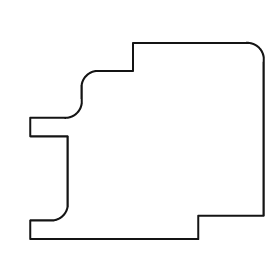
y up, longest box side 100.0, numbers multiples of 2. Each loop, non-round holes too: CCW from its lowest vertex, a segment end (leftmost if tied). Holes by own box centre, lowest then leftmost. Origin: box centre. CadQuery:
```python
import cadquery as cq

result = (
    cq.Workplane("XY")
    .moveTo(-50.0, -42.0)
    .lineTo(22.0, -42.0)
    .lineTo(22.0, -32.0)
    .lineTo(50.0, -32.0)
    .lineTo(50.0, 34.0)
    .threePointArc((48.0, 40.0), (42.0, 42.0))
    .lineTo(-6.0, 42.0)
    .lineTo(-6.0, 30.0)
    .lineTo(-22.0, 30.0)
    .threePointArc((-26.0, 28.0), (-28.0, 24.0))
    .lineTo(-28.0, 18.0)
    .threePointArc((-30.0, 12.0), (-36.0, 10.0))
    .lineTo(-50.0, 10.0)
    .lineTo(-50.0, 2.0)
    .lineTo(-34.0, 2.0)
    .lineTo(-34.0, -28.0)
    .threePointArc((-36.0, -32.0), (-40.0, -34.0))
    .lineTo(-50.0, -34.0)
    .close()
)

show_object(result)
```